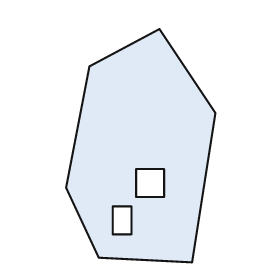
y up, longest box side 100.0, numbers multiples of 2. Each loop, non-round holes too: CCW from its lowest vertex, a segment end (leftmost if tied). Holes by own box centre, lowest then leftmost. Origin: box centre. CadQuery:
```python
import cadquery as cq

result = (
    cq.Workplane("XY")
    .moveTo(22.0, -50.0)
    .lineTo(32.0, 14.0)
    .lineTo(8.0, 50.0)
    .lineTo(-22.0, 34.0)
    .lineTo(-32.0, -18.0)
    .lineTo(-18.0, -48.0)
    .close()
    .moveTo(-12.0, -38.0)
    .lineTo(-4.0, -38.0)
    .lineTo(-4.0, -26.0)
    .lineTo(-12.0, -26.0)
    .close()
    .moveTo(-2.0, -22.0)
    .lineTo(10.0, -22.0)
    .lineTo(10.0, -10.0)
    .lineTo(-2.0, -10.0)
    .close()
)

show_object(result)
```